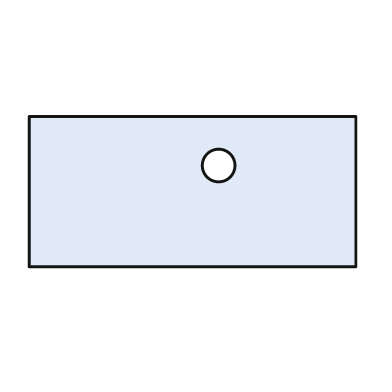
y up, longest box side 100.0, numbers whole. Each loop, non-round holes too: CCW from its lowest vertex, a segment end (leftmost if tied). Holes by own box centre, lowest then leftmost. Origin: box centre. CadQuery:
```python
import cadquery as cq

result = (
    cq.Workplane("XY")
    .moveTo(-50.0, -23.0)
    .lineTo(50.0, -23.0)
    .lineTo(50.0, 23.0)
    .lineTo(-50.0, 23.0)
    .close()
    .moveTo(8.0, 8.0)
    .circle(5.0)
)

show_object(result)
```